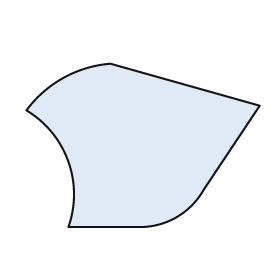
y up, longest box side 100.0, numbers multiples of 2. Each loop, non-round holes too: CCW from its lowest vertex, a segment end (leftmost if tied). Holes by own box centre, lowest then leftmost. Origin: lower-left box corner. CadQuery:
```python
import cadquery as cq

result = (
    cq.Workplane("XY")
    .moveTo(18.0, 0.0)
    .lineTo(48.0, 0.0)
    .threePointArc((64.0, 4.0), (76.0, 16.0))
    .lineTo(100.0, 52.0)
    .lineTo(36.0, 70.0)
    .threePointArc((16.0, 64.0), (0.0, 50.0))
    .threePointArc((18.0, 28.0), (18.0, 0.0))
    .close()
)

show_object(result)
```